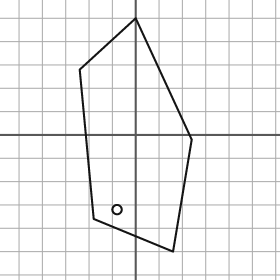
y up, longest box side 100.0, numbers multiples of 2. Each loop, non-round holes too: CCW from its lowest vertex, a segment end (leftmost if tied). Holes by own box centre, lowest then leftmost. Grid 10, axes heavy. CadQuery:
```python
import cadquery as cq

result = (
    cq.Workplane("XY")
    .moveTo(16.0, -50.0)
    .lineTo(24.0, -2.0)
    .lineTo(0.0, 50.0)
    .lineTo(-24.0, 28.0)
    .lineTo(-18.0, -36.0)
    .close()
    .moveTo(-8.0, -32.0)
    .circle(2.0)
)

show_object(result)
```